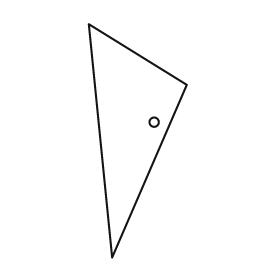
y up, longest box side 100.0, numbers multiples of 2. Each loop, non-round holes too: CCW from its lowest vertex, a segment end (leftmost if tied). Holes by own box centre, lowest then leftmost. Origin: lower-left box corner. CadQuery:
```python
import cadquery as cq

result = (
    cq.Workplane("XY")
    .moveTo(10.0, 0.0)
    .lineTo(42.0, 74.0)
    .lineTo(0.0, 100.0)
    .close()
    .moveTo(28.0, 58.0)
    .circle(2.0)
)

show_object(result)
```